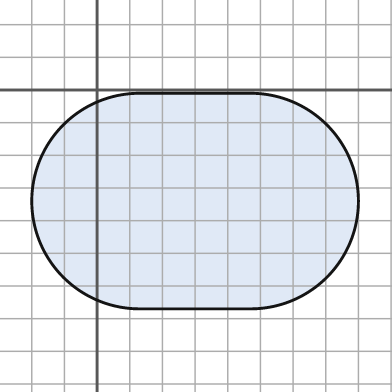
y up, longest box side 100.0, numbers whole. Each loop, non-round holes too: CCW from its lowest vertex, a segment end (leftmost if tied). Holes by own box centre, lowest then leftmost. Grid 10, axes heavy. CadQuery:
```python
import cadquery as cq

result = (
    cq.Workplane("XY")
    .moveTo(13.0, -67.0)
    .lineTo(47.0, -67.0)
    .threePointArc((80.0, -34.0), (47.0, -1.0))
    .lineTo(13.0, -1.0)
    .threePointArc((-20.0, -34.0), (13.0, -67.0))
    .close()
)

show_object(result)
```